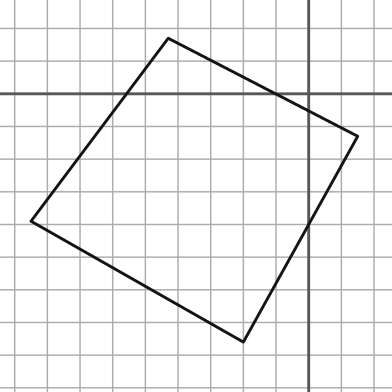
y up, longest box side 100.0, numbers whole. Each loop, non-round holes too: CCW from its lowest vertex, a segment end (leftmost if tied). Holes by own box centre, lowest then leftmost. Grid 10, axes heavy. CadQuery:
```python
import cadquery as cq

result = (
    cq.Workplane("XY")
    .moveTo(-20.0, -76.0)
    .lineTo(15.0, -13.0)
    .lineTo(-43.0, 17.0)
    .lineTo(-85.0, -39.0)
    .close()
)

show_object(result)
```